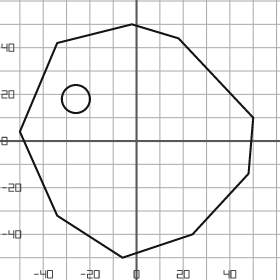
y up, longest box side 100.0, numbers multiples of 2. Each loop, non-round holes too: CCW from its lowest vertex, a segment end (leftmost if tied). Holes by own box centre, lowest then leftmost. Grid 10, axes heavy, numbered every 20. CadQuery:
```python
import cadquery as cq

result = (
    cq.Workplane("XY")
    .moveTo(-6.0, -50.0)
    .lineTo(24.0, -40.0)
    .lineTo(48.0, -14.0)
    .lineTo(50.0, 10.0)
    .lineTo(18.0, 44.0)
    .lineTo(-2.0, 50.0)
    .lineTo(-34.0, 42.0)
    .lineTo(-50.0, 4.0)
    .lineTo(-34.0, -32.0)
    .close()
    .moveTo(-26.0, 18.0)
    .circle(6.0)
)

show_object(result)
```